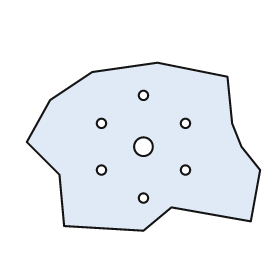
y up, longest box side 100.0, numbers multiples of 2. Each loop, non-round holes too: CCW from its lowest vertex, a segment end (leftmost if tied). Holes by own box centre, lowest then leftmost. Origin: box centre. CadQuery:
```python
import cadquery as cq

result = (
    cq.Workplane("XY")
    .moveTo(0.0, -36.0)
    .lineTo(12.0, -26.0)
    .lineTo(46.0, -32.0)
    .lineTo(50.0, -10.0)
    .lineTo(42.0, 0.0)
    .lineTo(38.0, 10.0)
    .lineTo(36.0, 30.0)
    .lineTo(6.0, 36.0)
    .lineTo(-22.0, 32.0)
    .lineTo(-40.0, 20.0)
    .lineTo(-50.0, 2.0)
    .lineTo(-36.0, -12.0)
    .lineTo(-34.0, -34.0)
    .close()
    .moveTo(0.0, -22.0)
    .circle(2.0)
    .moveTo(-18.0, -10.0)
    .circle(2.0)
    .moveTo(18.0, -10.0)
    .circle(2.0)
    .moveTo(0.0, 0.0)
    .circle(4.0)
    .moveTo(-18.0, 10.0)
    .circle(2.0)
    .moveTo(18.0, 10.0)
    .circle(2.0)
    .moveTo(0.0, 22.0)
    .circle(2.0)
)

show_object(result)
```